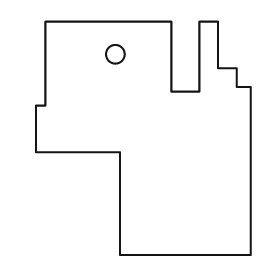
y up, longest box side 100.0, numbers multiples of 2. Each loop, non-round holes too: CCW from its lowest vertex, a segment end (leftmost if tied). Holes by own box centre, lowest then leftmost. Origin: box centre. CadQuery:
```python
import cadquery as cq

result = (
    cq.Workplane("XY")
    .moveTo(-10.0, -50.0)
    .lineTo(46.0, -50.0)
    .lineTo(46.0, 22.0)
    .lineTo(40.0, 22.0)
    .lineTo(40.0, 30.0)
    .lineTo(32.0, 30.0)
    .lineTo(32.0, 50.0)
    .lineTo(24.0, 50.0)
    .lineTo(24.0, 20.0)
    .lineTo(12.0, 20.0)
    .lineTo(12.0, 50.0)
    .lineTo(-42.0, 50.0)
    .lineTo(-42.0, 14.0)
    .lineTo(-46.0, 14.0)
    .lineTo(-46.0, -6.0)
    .lineTo(-10.0, -6.0)
    .close()
    .moveTo(-12.0, 36.0)
    .circle(4.0)
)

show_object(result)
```